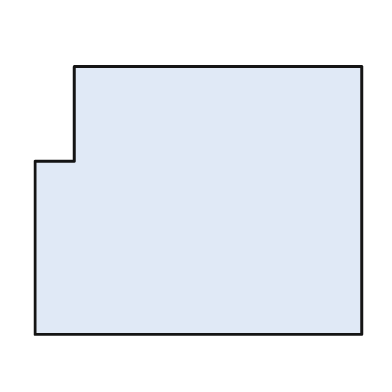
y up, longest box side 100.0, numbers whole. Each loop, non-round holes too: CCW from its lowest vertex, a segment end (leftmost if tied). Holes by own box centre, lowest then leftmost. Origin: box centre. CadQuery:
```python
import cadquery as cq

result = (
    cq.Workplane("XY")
    .moveTo(-50.0, -41.0)
    .lineTo(50.0, -41.0)
    .lineTo(50.0, 41.0)
    .lineTo(-38.0, 41.0)
    .lineTo(-38.0, 12.0)
    .lineTo(-50.0, 12.0)
    .close()
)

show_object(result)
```